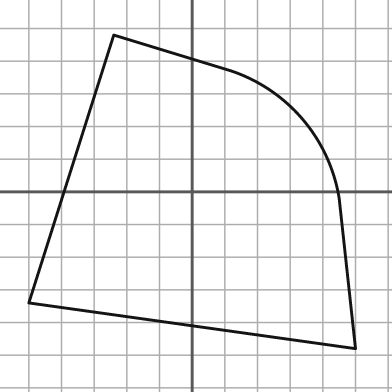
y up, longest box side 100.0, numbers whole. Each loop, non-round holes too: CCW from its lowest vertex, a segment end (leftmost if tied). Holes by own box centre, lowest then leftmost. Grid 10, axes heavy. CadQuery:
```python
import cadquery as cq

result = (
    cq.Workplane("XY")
    .moveTo(50.0, -48.0)
    .lineTo(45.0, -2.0)
    .threePointArc((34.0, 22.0), (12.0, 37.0))
    .lineTo(-24.0, 48.0)
    .lineTo(-50.0, -34.0)
    .close()
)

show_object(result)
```